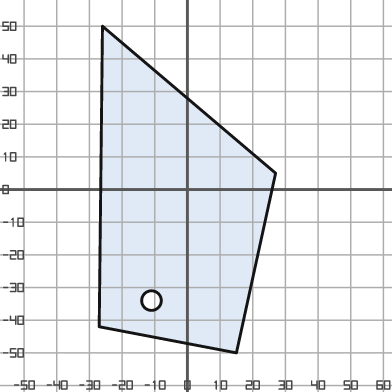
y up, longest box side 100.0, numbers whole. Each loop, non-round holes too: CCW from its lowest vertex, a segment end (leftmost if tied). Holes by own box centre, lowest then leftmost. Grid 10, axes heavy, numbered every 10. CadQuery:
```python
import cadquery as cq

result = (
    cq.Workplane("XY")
    .moveTo(15.0, -50.0)
    .lineTo(27.0, 5.0)
    .lineTo(-26.0, 50.0)
    .lineTo(-27.0, -42.0)
    .close()
    .moveTo(-11.0, -34.0)
    .circle(3.0)
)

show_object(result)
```